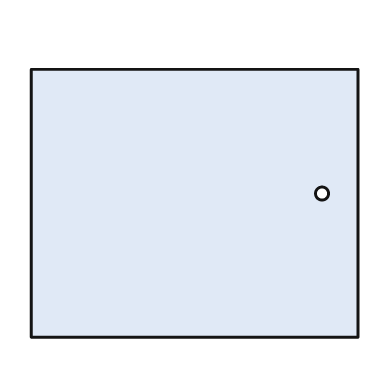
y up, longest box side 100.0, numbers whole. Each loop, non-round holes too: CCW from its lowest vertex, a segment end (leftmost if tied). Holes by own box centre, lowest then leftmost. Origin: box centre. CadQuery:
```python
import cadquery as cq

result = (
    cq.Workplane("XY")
    .moveTo(-50.0, -41.0)
    .lineTo(50.0, -41.0)
    .lineTo(50.0, 41.0)
    .lineTo(-50.0, 41.0)
    .close()
    .moveTo(39.0, 3.0)
    .circle(2.0)
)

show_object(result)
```